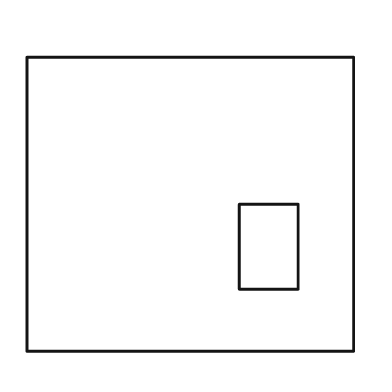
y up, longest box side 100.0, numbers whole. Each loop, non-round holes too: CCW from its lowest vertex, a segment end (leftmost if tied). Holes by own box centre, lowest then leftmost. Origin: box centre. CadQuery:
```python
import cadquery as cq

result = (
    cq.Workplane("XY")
    .moveTo(-50.0, -45.0)
    .lineTo(50.0, -45.0)
    .lineTo(50.0, 45.0)
    .lineTo(-50.0, 45.0)
    .close()
    .moveTo(15.0, -26.0)
    .lineTo(33.0, -26.0)
    .lineTo(33.0, 0.0)
    .lineTo(15.0, 0.0)
    .close()
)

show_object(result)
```